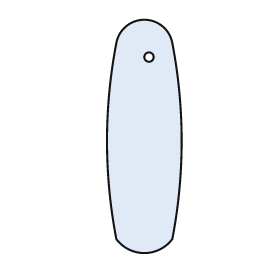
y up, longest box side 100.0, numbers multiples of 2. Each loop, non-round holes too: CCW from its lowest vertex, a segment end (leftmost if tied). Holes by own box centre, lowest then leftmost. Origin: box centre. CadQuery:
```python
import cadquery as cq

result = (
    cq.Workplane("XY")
    .moveTo(-12.0, -44.0)
    .threePointArc((0.0, -50.0), (12.0, -44.0))
    .threePointArc((16.0, -2.0), (12.0, 40.0))
    .threePointArc((0.0, 50.0), (-12.0, 40.0))
    .threePointArc((-16.0, -2.0), (-12.0, -44.0))
    .close()
    .moveTo(2.0, 34.0)
    .circle(2.0)
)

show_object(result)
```